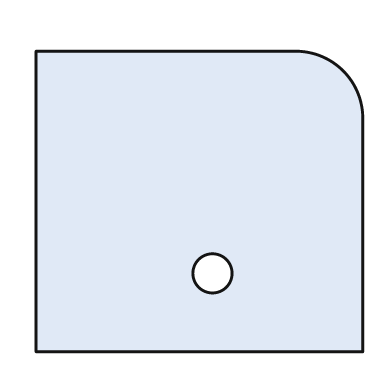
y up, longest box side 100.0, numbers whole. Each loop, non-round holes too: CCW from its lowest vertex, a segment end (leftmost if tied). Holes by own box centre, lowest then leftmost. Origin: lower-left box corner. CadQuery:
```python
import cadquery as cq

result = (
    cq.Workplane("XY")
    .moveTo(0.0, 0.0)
    .lineTo(100.0, 0.0)
    .lineTo(100.0, 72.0)
    .threePointArc((94.0, 86.0), (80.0, 92.0))
    .lineTo(0.0, 92.0)
    .close()
    .moveTo(54.0, 24.0)
    .circle(6.0)
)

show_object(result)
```